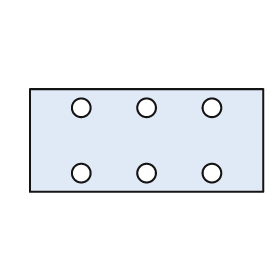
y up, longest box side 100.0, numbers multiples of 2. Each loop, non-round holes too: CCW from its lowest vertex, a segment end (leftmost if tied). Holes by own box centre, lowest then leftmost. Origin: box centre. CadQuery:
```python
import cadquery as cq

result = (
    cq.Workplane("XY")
    .moveTo(-50.0, -22.0)
    .lineTo(50.0, -22.0)
    .lineTo(50.0, 22.0)
    .lineTo(-50.0, 22.0)
    .close()
    .moveTo(-28.0, -14.0)
    .circle(4.0)
    .moveTo(0.0, -14.0)
    .circle(4.0)
    .moveTo(28.0, -14.0)
    .circle(4.0)
    .moveTo(-28.0, 14.0)
    .circle(4.0)
    .moveTo(0.0, 14.0)
    .circle(4.0)
    .moveTo(28.0, 14.0)
    .circle(4.0)
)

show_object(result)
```